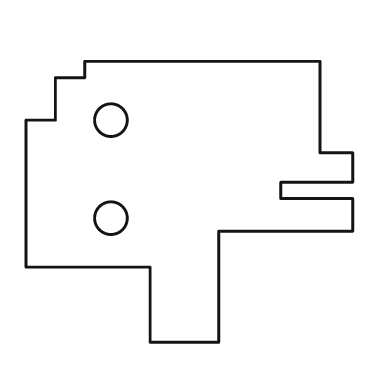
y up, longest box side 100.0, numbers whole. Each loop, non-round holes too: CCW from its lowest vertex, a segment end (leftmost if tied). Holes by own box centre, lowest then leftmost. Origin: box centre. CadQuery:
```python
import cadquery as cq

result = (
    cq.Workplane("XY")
    .moveTo(-12.0, -43.0)
    .lineTo(9.0, -43.0)
    .lineTo(9.0, -9.0)
    .lineTo(50.0, -9.0)
    .lineTo(50.0, 1.0)
    .lineTo(28.0, 1.0)
    .lineTo(28.0, 6.0)
    .lineTo(50.0, 6.0)
    .lineTo(50.0, 15.0)
    .lineTo(40.0, 15.0)
    .lineTo(40.0, 43.0)
    .lineTo(-32.0, 43.0)
    .lineTo(-32.0, 38.0)
    .lineTo(-41.0, 38.0)
    .lineTo(-41.0, 25.0)
    .lineTo(-50.0, 25.0)
    .lineTo(-50.0, -20.0)
    .lineTo(-12.0, -20.0)
    .close()
    .moveTo(-24.0, -5.0)
    .circle(5.0)
    .moveTo(-24.0, 25.0)
    .circle(5.0)
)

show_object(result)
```